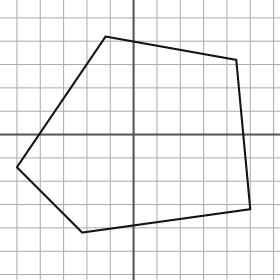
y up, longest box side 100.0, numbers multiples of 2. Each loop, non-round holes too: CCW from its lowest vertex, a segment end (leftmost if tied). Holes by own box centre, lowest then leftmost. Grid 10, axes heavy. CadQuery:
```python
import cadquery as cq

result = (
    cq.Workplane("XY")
    .moveTo(-22.0, -42.0)
    .lineTo(50.0, -32.0)
    .lineTo(44.0, 32.0)
    .lineTo(-12.0, 42.0)
    .lineTo(-50.0, -14.0)
    .close()
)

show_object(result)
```